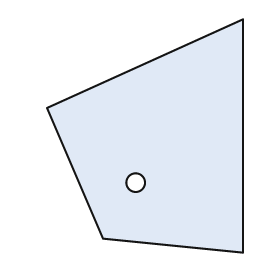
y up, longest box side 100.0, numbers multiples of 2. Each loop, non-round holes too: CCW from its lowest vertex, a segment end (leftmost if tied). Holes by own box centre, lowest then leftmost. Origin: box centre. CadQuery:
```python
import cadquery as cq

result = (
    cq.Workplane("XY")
    .moveTo(42.0, -50.0)
    .lineTo(42.0, 50.0)
    .lineTo(-42.0, 12.0)
    .lineTo(-18.0, -44.0)
    .close()
    .moveTo(-4.0, -20.0)
    .circle(4.0)
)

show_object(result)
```